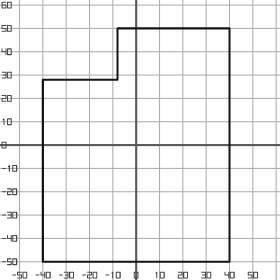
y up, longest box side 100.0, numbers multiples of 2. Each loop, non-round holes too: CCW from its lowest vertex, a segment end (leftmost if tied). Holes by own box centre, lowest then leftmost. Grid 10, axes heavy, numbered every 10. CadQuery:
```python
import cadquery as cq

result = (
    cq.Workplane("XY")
    .moveTo(-40.0, -50.0)
    .lineTo(40.0, -50.0)
    .lineTo(40.0, 50.0)
    .lineTo(-8.0, 50.0)
    .lineTo(-8.0, 28.0)
    .lineTo(-40.0, 28.0)
    .close()
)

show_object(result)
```